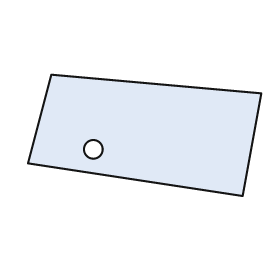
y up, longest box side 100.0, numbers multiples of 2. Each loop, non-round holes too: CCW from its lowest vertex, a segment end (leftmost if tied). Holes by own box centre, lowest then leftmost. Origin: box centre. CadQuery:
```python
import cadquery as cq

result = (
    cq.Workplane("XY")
    .moveTo(42.0, -26.0)
    .lineTo(50.0, 18.0)
    .lineTo(-40.0, 26.0)
    .lineTo(-50.0, -12.0)
    .close()
    .moveTo(-22.0, -6.0)
    .circle(4.0)
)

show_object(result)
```